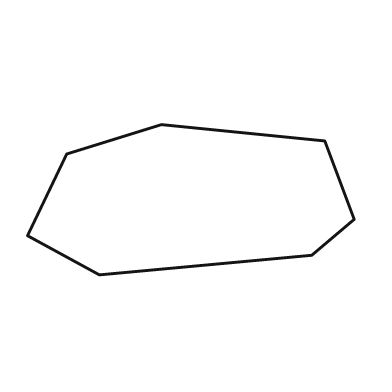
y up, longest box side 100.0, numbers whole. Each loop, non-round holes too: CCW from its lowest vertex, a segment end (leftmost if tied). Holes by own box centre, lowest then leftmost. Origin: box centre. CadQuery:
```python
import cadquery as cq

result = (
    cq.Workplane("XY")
    .moveTo(-28.0, -23.0)
    .lineTo(37.0, -17.0)
    .lineTo(50.0, -6.0)
    .lineTo(41.0, 18.0)
    .lineTo(-9.0, 23.0)
    .lineTo(-38.0, 14.0)
    .lineTo(-50.0, -11.0)
    .close()
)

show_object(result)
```